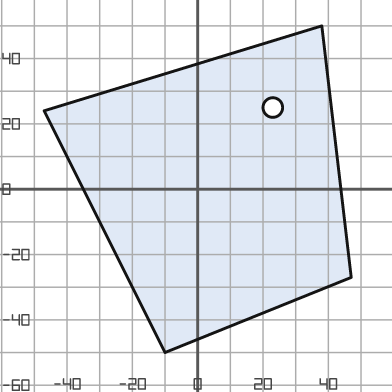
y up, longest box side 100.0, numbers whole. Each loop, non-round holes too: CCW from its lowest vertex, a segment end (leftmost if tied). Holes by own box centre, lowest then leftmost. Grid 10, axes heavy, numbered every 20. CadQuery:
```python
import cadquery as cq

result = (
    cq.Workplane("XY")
    .moveTo(-10.0, -50.0)
    .lineTo(47.0, -27.0)
    .lineTo(38.0, 50.0)
    .lineTo(-47.0, 24.0)
    .close()
    .moveTo(23.0, 25.0)
    .circle(3.0)
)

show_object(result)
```